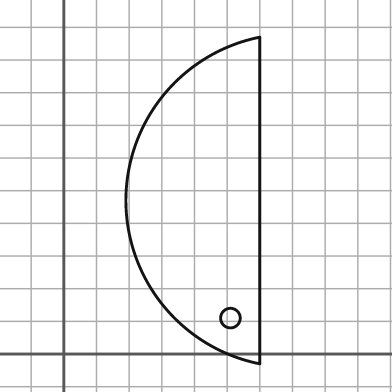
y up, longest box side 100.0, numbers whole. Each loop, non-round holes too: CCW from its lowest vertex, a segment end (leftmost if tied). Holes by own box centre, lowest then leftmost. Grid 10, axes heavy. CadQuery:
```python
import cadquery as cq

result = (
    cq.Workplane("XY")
    .moveTo(60.0, -3.0)
    .lineTo(60.0, 97.0)
    .threePointArc((19.0, 47.0), (60.0, -3.0))
    .close()
    .moveTo(51.0, 11.0)
    .circle(3.0)
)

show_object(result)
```